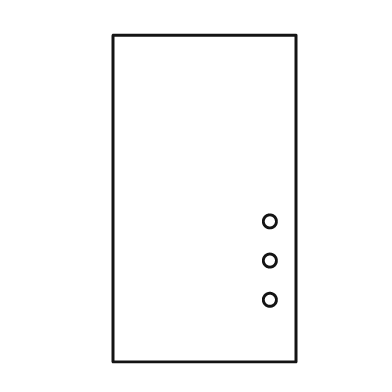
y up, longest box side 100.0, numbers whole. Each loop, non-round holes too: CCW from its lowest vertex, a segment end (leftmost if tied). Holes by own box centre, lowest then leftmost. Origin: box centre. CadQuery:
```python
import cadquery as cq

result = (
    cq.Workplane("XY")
    .moveTo(-28.0, -50.0)
    .lineTo(28.0, -50.0)
    .lineTo(28.0, 50.0)
    .lineTo(-28.0, 50.0)
    .close()
    .moveTo(20.0, -31.0)
    .circle(2.0)
    .moveTo(20.0, -19.0)
    .circle(2.0)
    .moveTo(20.0, -7.0)
    .circle(2.0)
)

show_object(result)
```